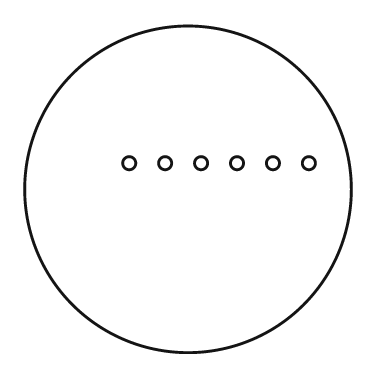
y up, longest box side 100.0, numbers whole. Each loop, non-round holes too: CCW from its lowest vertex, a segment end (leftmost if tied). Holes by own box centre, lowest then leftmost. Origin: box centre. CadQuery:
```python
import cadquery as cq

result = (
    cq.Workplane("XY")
    .moveTo(0.0, 0.0)
    .circle(50.0)
    .moveTo(-18.0, 8.0)
    .circle(2.0)
    .moveTo(-7.0, 8.0)
    .circle(2.0)
    .moveTo(4.0, 8.0)
    .circle(2.0)
    .moveTo(15.0, 8.0)
    .circle(2.0)
    .moveTo(26.0, 8.0)
    .circle(2.0)
    .moveTo(37.0, 8.0)
    .circle(2.0)
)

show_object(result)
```